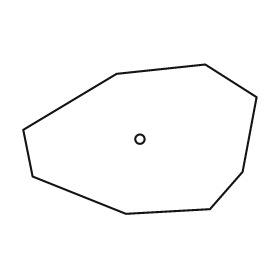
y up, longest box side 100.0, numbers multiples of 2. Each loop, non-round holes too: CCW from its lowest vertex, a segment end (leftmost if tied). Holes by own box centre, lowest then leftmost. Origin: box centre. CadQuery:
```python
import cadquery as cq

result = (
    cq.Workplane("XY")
    .moveTo(-6.0, -32.0)
    .lineTo(30.0, -30.0)
    .lineTo(44.0, -14.0)
    .lineTo(50.0, 18.0)
    .lineTo(28.0, 32.0)
    .lineTo(-10.0, 28.0)
    .lineTo(-50.0, 4.0)
    .lineTo(-46.0, -16.0)
    .close()
    .moveTo(0.0, 0.0)
    .circle(2.0)
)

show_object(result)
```